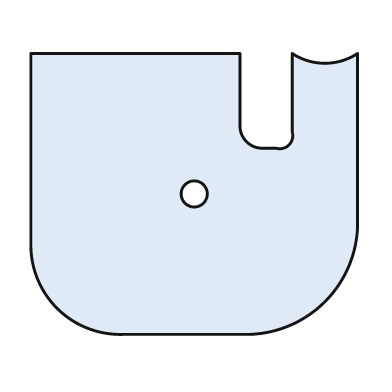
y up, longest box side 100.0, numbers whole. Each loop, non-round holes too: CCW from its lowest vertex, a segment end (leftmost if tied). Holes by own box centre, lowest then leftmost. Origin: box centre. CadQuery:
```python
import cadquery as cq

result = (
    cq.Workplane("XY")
    .moveTo(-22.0, -43.0)
    .lineTo(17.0, -43.0)
    .threePointArc((40.0, -33.0), (50.0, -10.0))
    .lineTo(50.0, 43.0)
    .threePointArc((40.0, 40.0), (30.0, 43.0))
    .lineTo(30.0, 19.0)
    .threePointArc((29.0, 15.0), (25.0, 14.0))
    .lineTo(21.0, 14.0)
    .threePointArc((16.0, 16.0), (14.0, 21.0))
    .lineTo(14.0, 43.0)
    .lineTo(-50.0, 43.0)
    .lineTo(-50.0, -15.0)
    .threePointArc((-42.0, -35.0), (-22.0, -43.0))
    .close()
    .moveTo(0.0, 0.0)
    .circle(4.0)
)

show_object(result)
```